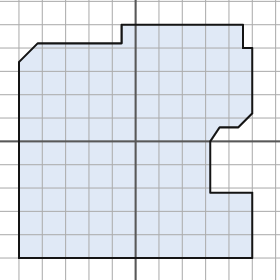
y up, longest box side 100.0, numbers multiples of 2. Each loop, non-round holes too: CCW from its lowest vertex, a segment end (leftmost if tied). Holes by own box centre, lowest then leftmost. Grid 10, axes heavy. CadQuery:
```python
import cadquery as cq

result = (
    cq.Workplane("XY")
    .moveTo(-50.0, -50.0)
    .lineTo(50.0, -50.0)
    .lineTo(50.0, -22.0)
    .lineTo(32.0, -22.0)
    .lineTo(32.0, 0.0)
    .lineTo(36.0, 6.0)
    .lineTo(44.0, 6.0)
    .lineTo(50.0, 12.0)
    .lineTo(50.0, 40.0)
    .lineTo(46.0, 40.0)
    .lineTo(46.0, 50.0)
    .lineTo(-6.0, 50.0)
    .lineTo(-6.0, 42.0)
    .lineTo(-42.0, 42.0)
    .lineTo(-50.0, 34.0)
    .close()
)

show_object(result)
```